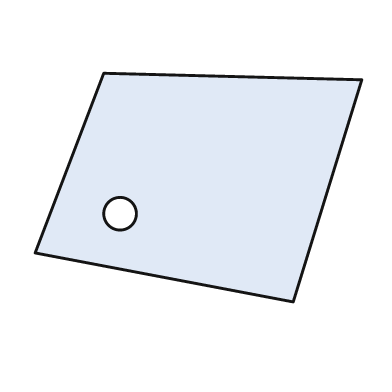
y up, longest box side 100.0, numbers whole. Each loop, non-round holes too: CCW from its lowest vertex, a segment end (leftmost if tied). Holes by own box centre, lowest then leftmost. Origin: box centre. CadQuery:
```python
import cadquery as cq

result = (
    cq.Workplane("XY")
    .moveTo(29.0, -35.0)
    .lineTo(50.0, 33.0)
    .lineTo(-29.0, 35.0)
    .lineTo(-50.0, -20.0)
    .close()
    .moveTo(-24.0, -8.0)
    .circle(5.0)
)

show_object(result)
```